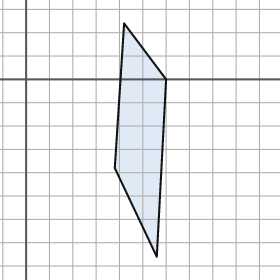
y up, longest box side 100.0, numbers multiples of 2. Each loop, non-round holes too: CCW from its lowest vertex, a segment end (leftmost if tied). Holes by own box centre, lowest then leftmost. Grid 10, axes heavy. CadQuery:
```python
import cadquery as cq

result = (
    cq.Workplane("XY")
    .moveTo(56.0, -76.0)
    .lineTo(60.0, 0.0)
    .lineTo(42.0, 24.0)
    .lineTo(38.0, -38.0)
    .close()
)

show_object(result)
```